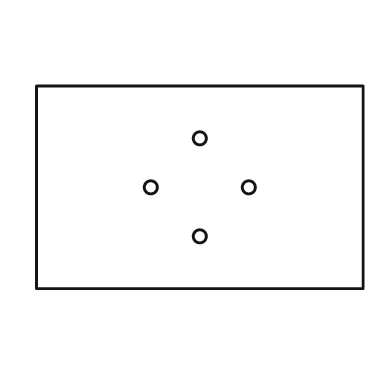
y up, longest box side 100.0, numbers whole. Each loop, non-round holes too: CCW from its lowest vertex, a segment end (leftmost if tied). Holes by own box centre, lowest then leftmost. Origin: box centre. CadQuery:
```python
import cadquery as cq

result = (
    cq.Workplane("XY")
    .moveTo(-50.0, -31.0)
    .lineTo(50.0, -31.0)
    .lineTo(50.0, 31.0)
    .lineTo(-50.0, 31.0)
    .close()
    .moveTo(0.0, -15.0)
    .circle(2.0)
    .moveTo(-15.0, 0.0)
    .circle(2.0)
    .moveTo(15.0, 0.0)
    .circle(2.0)
    .moveTo(0.0, 15.0)
    .circle(2.0)
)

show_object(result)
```